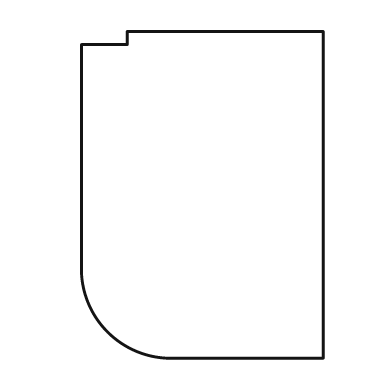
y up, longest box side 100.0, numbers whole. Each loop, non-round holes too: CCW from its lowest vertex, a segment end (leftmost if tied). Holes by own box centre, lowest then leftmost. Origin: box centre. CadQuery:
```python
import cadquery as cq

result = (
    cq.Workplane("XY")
    .moveTo(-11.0, -50.0)
    .lineTo(37.0, -50.0)
    .lineTo(37.0, 50.0)
    .lineTo(-23.0, 50.0)
    .lineTo(-23.0, 46.0)
    .lineTo(-37.0, 46.0)
    .lineTo(-37.0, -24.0)
    .threePointArc((-29.0, -42.0), (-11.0, -50.0))
    .close()
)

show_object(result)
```